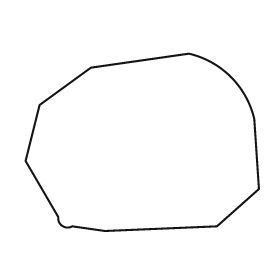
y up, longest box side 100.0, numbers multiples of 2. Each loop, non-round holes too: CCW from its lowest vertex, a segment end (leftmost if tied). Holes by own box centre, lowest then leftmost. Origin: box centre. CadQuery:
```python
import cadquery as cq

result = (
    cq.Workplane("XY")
    .moveTo(-16.0, -38.0)
    .lineTo(32.0, -36.0)
    .lineTo(50.0, -20.0)
    .lineTo(48.0, 10.0)
    .threePointArc((38.0, 28.0), (20.0, 38.0))
    .lineTo(-22.0, 32.0)
    .lineTo(-44.0, 16.0)
    .lineTo(-50.0, -8.0)
    .lineTo(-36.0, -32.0)
    .threePointArc((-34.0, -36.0), (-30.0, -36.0))
    .close()
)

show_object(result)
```